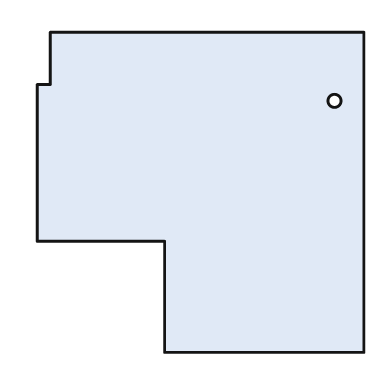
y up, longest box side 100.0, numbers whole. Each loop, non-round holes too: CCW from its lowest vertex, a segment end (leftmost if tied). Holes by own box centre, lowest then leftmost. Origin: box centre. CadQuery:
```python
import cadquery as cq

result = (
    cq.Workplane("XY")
    .moveTo(-11.0, -49.0)
    .lineTo(50.0, -49.0)
    .lineTo(50.0, 49.0)
    .lineTo(-46.0, 49.0)
    .lineTo(-46.0, 33.0)
    .lineTo(-50.0, 33.0)
    .lineTo(-50.0, -15.0)
    .lineTo(-11.0, -15.0)
    .close()
    .moveTo(41.0, 28.0)
    .circle(2.0)
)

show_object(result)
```